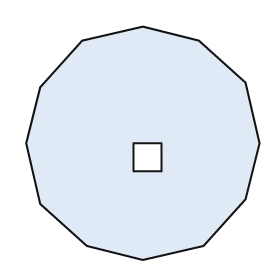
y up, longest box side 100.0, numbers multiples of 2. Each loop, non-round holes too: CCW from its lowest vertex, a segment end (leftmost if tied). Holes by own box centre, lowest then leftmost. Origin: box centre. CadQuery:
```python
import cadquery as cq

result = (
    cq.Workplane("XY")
    .moveTo(0.0, -50.0)
    .lineTo(26.0, -44.0)
    .lineTo(44.0, -24.0)
    .lineTo(50.0, 0.0)
    .lineTo(44.0, 26.0)
    .lineTo(24.0, 44.0)
    .lineTo(0.0, 50.0)
    .lineTo(-26.0, 44.0)
    .lineTo(-44.0, 24.0)
    .lineTo(-50.0, 0.0)
    .lineTo(-44.0, -26.0)
    .lineTo(-24.0, -44.0)
    .close()
    .moveTo(-4.0, -12.0)
    .lineTo(8.0, -12.0)
    .lineTo(8.0, 0.0)
    .lineTo(-4.0, 0.0)
    .close()
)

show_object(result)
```